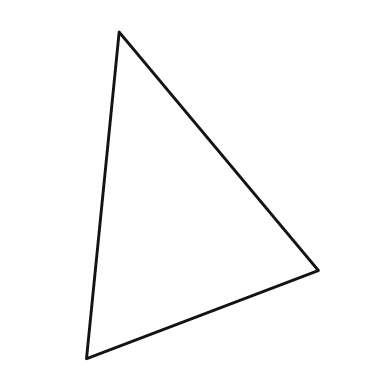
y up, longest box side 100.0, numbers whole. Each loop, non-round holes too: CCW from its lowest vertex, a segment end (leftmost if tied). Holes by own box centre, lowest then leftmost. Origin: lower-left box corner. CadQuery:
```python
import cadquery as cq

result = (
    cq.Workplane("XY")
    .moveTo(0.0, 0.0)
    .lineTo(71.0, 27.0)
    .lineTo(10.0, 100.0)
    .close()
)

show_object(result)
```